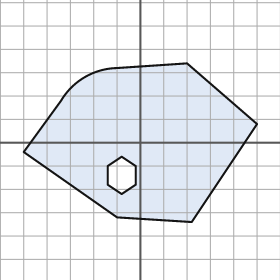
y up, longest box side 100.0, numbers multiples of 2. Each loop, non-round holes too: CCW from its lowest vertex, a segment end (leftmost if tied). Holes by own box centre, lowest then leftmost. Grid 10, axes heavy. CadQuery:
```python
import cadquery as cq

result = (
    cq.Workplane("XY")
    .moveTo(22.0, -34.0)
    .lineTo(50.0, 8.0)
    .lineTo(20.0, 34.0)
    .lineTo(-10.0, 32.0)
    .threePointArc((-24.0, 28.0), (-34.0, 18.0))
    .lineTo(-50.0, -4.0)
    .lineTo(-10.0, -32.0)
    .close()
    .moveTo(-8.0, -22.0)
    .lineTo(-2.0, -18.0)
    .lineTo(-2.0, -10.0)
    .lineTo(-8.0, -6.0)
    .lineTo(-14.0, -10.0)
    .lineTo(-14.0, -18.0)
    .close()
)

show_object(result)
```